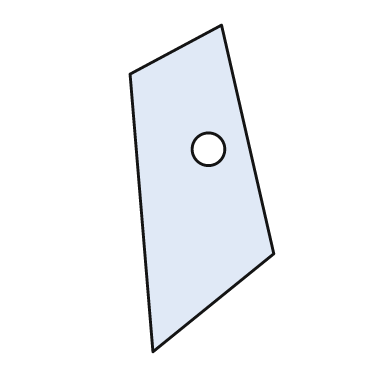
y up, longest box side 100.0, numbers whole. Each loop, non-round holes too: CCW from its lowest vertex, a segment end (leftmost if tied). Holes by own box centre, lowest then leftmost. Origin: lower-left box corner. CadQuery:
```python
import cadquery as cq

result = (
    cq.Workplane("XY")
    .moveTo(7.0, 0.0)
    .lineTo(44.0, 30.0)
    .lineTo(28.0, 100.0)
    .lineTo(0.0, 85.0)
    .close()
    .moveTo(24.0, 62.0)
    .circle(5.0)
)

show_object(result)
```